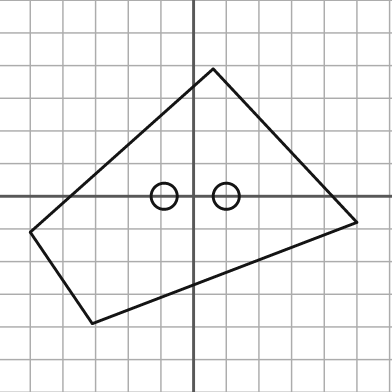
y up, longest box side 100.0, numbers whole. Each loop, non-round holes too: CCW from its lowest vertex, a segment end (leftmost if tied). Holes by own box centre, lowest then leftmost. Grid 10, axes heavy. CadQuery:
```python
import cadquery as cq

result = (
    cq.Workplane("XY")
    .moveTo(-31.0, -39.0)
    .lineTo(50.0, -8.0)
    .lineTo(6.0, 39.0)
    .lineTo(-50.0, -11.0)
    .close()
    .moveTo(-9.0, 0.0)
    .circle(4.0)
    .moveTo(10.0, 0.0)
    .circle(4.0)
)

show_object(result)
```